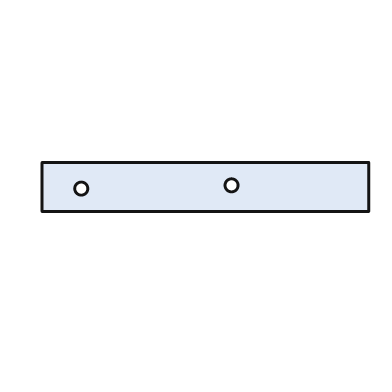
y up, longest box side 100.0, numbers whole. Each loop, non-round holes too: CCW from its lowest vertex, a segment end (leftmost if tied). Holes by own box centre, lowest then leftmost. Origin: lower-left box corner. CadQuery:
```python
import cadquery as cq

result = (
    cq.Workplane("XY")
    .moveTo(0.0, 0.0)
    .lineTo(100.0, 0.0)
    .lineTo(100.0, 15.0)
    .lineTo(0.0, 15.0)
    .close()
    .moveTo(12.0, 7.0)
    .circle(2.0)
    .moveTo(58.0, 8.0)
    .circle(2.0)
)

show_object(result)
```